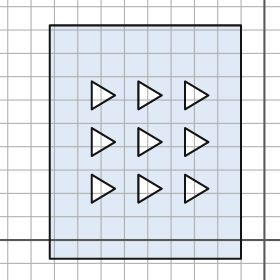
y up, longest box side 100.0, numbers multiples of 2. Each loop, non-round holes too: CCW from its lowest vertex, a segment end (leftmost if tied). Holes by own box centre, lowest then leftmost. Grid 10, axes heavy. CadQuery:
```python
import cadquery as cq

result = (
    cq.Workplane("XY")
    .moveTo(-92.0, -8.0)
    .lineTo(-10.0, -8.0)
    .lineTo(-10.0, 92.0)
    .lineTo(-92.0, 92.0)
    .close()
    .moveTo(-74.0, 16.0)
    .lineTo(-64.0, 22.0)
    .lineTo(-74.0, 28.0)
    .close()
    .moveTo(-54.0, 16.0)
    .lineTo(-44.0, 22.0)
    .lineTo(-54.0, 28.0)
    .close()
    .moveTo(-34.0, 16.0)
    .lineTo(-24.0, 22.0)
    .lineTo(-34.0, 28.0)
    .close()
    .moveTo(-74.0, 36.0)
    .lineTo(-64.0, 42.0)
    .lineTo(-74.0, 48.0)
    .close()
    .moveTo(-54.0, 36.0)
    .lineTo(-44.0, 42.0)
    .lineTo(-54.0, 48.0)
    .close()
    .moveTo(-34.0, 36.0)
    .lineTo(-24.0, 42.0)
    .lineTo(-34.0, 48.0)
    .close()
    .moveTo(-74.0, 56.0)
    .lineTo(-64.0, 62.0)
    .lineTo(-74.0, 68.0)
    .close()
    .moveTo(-54.0, 56.0)
    .lineTo(-44.0, 62.0)
    .lineTo(-54.0, 68.0)
    .close()
    .moveTo(-34.0, 56.0)
    .lineTo(-24.0, 62.0)
    .lineTo(-34.0, 68.0)
    .close()
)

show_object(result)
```